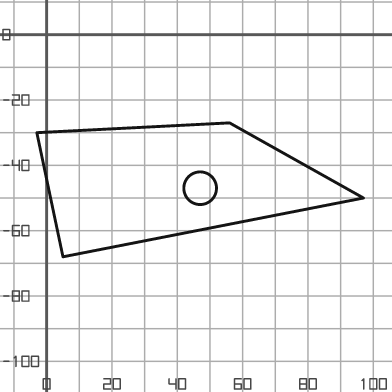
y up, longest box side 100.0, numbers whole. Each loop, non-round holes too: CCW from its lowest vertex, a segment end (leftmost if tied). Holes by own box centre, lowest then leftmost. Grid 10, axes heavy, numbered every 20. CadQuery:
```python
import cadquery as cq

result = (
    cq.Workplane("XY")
    .moveTo(5.0, -68.0)
    .lineTo(97.0, -50.0)
    .lineTo(56.0, -27.0)
    .lineTo(-3.0, -30.0)
    .close()
    .moveTo(47.0, -47.0)
    .circle(5.0)
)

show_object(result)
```